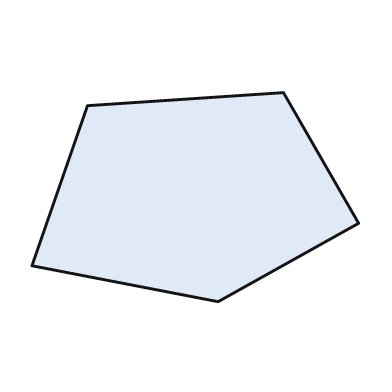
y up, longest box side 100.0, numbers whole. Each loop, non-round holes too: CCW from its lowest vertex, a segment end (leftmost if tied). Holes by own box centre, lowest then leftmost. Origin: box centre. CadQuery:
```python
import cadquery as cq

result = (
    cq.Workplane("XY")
    .moveTo(7.0, -32.0)
    .lineTo(50.0, -8.0)
    .lineTo(27.0, 32.0)
    .lineTo(-33.0, 28.0)
    .lineTo(-50.0, -21.0)
    .close()
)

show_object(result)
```